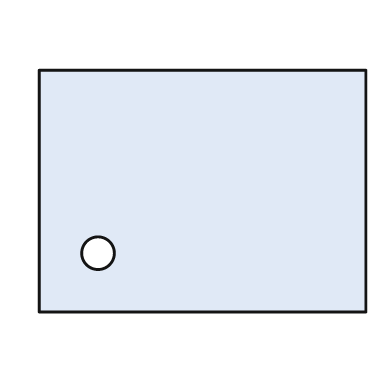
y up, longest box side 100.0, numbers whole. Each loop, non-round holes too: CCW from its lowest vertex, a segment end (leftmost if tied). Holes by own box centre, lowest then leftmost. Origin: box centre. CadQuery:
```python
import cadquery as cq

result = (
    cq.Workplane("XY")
    .moveTo(-50.0, -37.0)
    .lineTo(50.0, -37.0)
    .lineTo(50.0, 37.0)
    .lineTo(-50.0, 37.0)
    .close()
    .moveTo(-32.0, -19.0)
    .circle(5.0)
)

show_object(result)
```